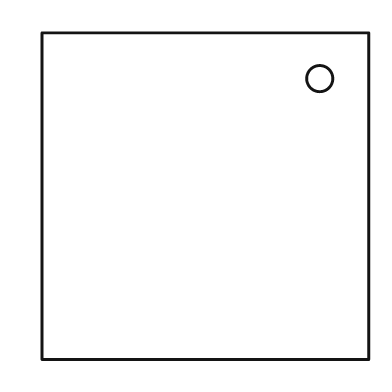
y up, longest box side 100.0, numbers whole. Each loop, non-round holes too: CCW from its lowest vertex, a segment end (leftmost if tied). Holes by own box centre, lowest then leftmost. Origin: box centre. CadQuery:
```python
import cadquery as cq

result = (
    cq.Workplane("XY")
    .moveTo(-50.0, -50.0)
    .lineTo(50.0, -50.0)
    .lineTo(50.0, 50.0)
    .lineTo(-50.0, 50.0)
    .close()
    .moveTo(35.0, 36.0)
    .circle(4.0)
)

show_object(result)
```